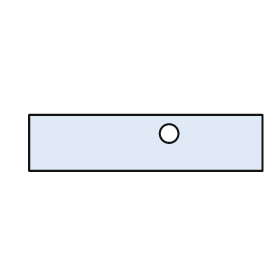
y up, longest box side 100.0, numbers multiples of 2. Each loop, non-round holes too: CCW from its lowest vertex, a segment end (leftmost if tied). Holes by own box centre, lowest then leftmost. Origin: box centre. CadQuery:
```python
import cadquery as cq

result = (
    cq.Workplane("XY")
    .moveTo(-50.0, -12.0)
    .lineTo(50.0, -12.0)
    .lineTo(50.0, 12.0)
    .lineTo(-50.0, 12.0)
    .close()
    .moveTo(10.0, 4.0)
    .circle(4.0)
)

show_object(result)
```